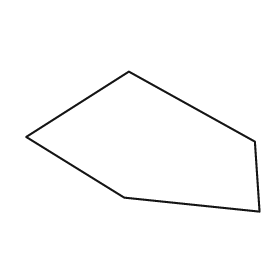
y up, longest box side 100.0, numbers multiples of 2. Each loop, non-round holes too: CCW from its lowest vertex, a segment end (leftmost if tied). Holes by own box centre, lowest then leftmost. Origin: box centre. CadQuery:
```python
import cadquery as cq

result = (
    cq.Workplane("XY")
    .moveTo(50.0, -30.0)
    .lineTo(48.0, 0.0)
    .lineTo(-6.0, 30.0)
    .lineTo(-50.0, 2.0)
    .lineTo(-8.0, -24.0)
    .close()
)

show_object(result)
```